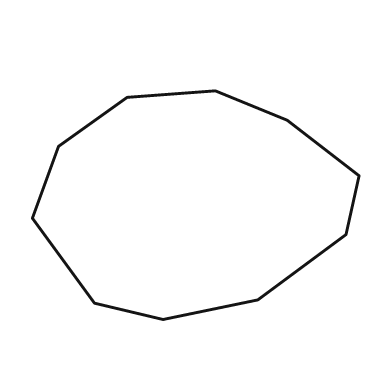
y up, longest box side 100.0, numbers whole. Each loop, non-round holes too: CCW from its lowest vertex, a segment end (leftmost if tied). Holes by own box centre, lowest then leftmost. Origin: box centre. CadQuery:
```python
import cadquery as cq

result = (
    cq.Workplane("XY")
    .moveTo(-10.0, -35.0)
    .lineTo(19.0, -29.0)
    .lineTo(46.0, -9.0)
    .lineTo(50.0, 9.0)
    .lineTo(28.0, 26.0)
    .lineTo(6.0, 35.0)
    .lineTo(-21.0, 33.0)
    .lineTo(-42.0, 18.0)
    .lineTo(-50.0, -4.0)
    .lineTo(-31.0, -30.0)
    .close()
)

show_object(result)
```